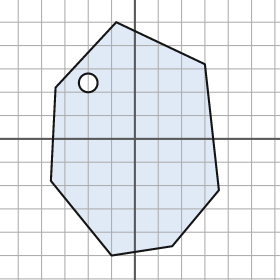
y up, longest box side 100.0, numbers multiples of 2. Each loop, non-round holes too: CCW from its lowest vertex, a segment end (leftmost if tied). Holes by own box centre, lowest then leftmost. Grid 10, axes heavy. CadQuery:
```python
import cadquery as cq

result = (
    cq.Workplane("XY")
    .moveTo(-10.0, -50.0)
    .lineTo(16.0, -46.0)
    .lineTo(36.0, -22.0)
    .lineTo(30.0, 32.0)
    .lineTo(-8.0, 50.0)
    .lineTo(-34.0, 22.0)
    .lineTo(-36.0, -18.0)
    .close()
    .moveTo(-20.0, 24.0)
    .circle(4.0)
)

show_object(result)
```